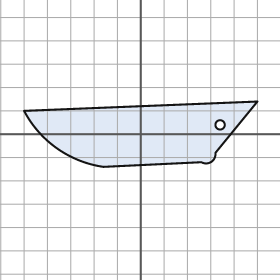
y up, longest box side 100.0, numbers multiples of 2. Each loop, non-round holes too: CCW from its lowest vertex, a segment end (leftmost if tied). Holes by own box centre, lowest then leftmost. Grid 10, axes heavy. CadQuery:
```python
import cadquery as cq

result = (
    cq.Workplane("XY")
    .moveTo(-16.0, -14.0)
    .lineTo(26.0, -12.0)
    .threePointArc((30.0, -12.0), (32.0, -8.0))
    .lineTo(50.0, 14.0)
    .lineTo(-50.0, 10.0)
    .threePointArc((-36.0, -6.0), (-16.0, -14.0))
    .close()
    .moveTo(34.0, 4.0)
    .circle(2.0)
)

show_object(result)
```